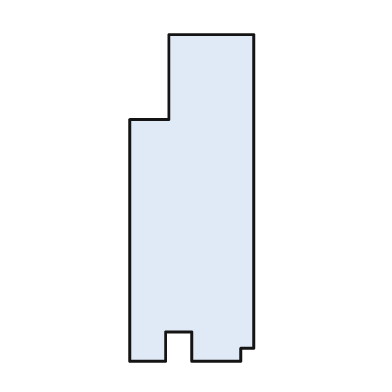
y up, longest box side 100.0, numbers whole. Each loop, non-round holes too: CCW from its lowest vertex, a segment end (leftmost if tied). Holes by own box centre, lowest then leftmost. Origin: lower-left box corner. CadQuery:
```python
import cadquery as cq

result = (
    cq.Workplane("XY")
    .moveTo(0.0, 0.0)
    .lineTo(11.0, 0.0)
    .lineTo(11.0, 9.0)
    .lineTo(19.0, 9.0)
    .lineTo(19.0, 0.0)
    .lineTo(34.0, 0.0)
    .lineTo(34.0, 4.0)
    .lineTo(38.0, 4.0)
    .lineTo(38.0, 100.0)
    .lineTo(12.0, 100.0)
    .lineTo(12.0, 74.0)
    .lineTo(0.0, 74.0)
    .close()
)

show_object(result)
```